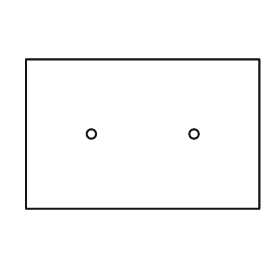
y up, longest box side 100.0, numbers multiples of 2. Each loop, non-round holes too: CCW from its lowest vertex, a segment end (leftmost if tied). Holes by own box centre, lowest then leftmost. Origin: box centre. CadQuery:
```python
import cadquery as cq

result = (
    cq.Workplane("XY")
    .moveTo(-50.0, -32.0)
    .lineTo(50.0, -32.0)
    .lineTo(50.0, 32.0)
    .lineTo(-50.0, 32.0)
    .close()
    .moveTo(-22.0, 0.0)
    .circle(2.0)
    .moveTo(22.0, 0.0)
    .circle(2.0)
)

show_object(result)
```